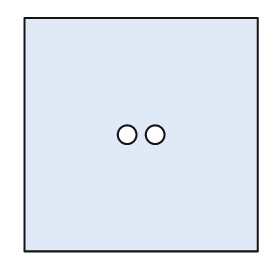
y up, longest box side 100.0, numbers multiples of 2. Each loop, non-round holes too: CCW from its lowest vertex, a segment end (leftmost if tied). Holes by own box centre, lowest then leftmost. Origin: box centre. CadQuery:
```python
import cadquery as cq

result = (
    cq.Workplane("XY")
    .moveTo(-50.0, -50.0)
    .lineTo(50.0, -50.0)
    .lineTo(50.0, 50.0)
    .lineTo(-50.0, 50.0)
    .close()
    .moveTo(-6.0, 0.0)
    .circle(4.0)
    .moveTo(6.0, 0.0)
    .circle(4.0)
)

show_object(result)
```